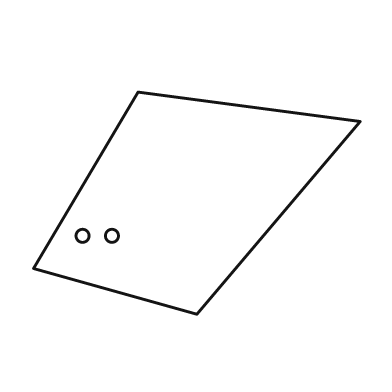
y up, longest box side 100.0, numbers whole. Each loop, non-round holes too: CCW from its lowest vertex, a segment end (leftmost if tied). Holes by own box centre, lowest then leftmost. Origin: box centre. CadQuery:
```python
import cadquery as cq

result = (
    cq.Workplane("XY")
    .moveTo(0.0, -34.0)
    .lineTo(50.0, 25.0)
    .lineTo(-18.0, 34.0)
    .lineTo(-50.0, -20.0)
    .close()
    .moveTo(-35.0, -10.0)
    .circle(2.0)
    .moveTo(-26.0, -10.0)
    .circle(2.0)
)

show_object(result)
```